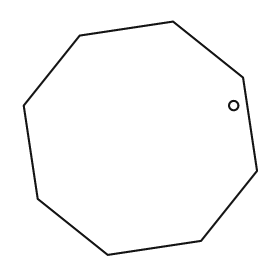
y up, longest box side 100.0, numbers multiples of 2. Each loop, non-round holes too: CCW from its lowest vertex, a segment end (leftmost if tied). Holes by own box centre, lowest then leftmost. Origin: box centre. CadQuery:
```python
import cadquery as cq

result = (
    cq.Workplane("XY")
    .moveTo(-14.0, -50.0)
    .lineTo(26.0, -44.0)
    .lineTo(50.0, -14.0)
    .lineTo(44.0, 26.0)
    .lineTo(14.0, 50.0)
    .lineTo(-26.0, 44.0)
    .lineTo(-50.0, 14.0)
    .lineTo(-44.0, -26.0)
    .close()
    .moveTo(40.0, 14.0)
    .circle(2.0)
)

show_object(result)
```